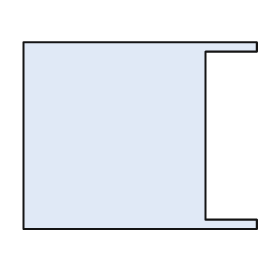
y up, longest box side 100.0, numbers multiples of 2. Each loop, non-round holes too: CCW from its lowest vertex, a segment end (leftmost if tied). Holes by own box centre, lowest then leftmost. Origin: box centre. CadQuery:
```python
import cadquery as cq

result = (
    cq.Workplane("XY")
    .moveTo(-50.0, -40.0)
    .lineTo(50.0, -40.0)
    .lineTo(50.0, -36.0)
    .lineTo(28.0, -36.0)
    .lineTo(28.0, 36.0)
    .lineTo(50.0, 36.0)
    .lineTo(50.0, 40.0)
    .lineTo(-50.0, 40.0)
    .close()
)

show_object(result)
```